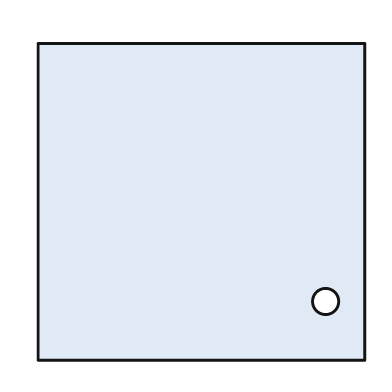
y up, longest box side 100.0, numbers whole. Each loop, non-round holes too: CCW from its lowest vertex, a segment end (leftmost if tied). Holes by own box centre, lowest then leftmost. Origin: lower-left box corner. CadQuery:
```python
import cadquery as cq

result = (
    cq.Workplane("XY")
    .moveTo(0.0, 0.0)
    .lineTo(100.0, 0.0)
    .lineTo(100.0, 97.0)
    .lineTo(0.0, 97.0)
    .close()
    .moveTo(88.0, 18.0)
    .circle(4.0)
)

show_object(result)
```